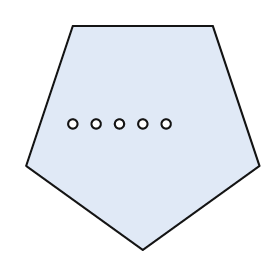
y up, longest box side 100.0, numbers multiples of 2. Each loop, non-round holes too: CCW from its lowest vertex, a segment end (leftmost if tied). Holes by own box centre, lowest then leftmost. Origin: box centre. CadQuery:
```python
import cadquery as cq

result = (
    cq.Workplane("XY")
    .moveTo(0.0, -48.0)
    .lineTo(50.0, -12.0)
    .lineTo(30.0, 48.0)
    .lineTo(-30.0, 48.0)
    .lineTo(-50.0, -12.0)
    .close()
    .moveTo(-30.0, 6.0)
    .circle(2.0)
    .moveTo(-20.0, 6.0)
    .circle(2.0)
    .moveTo(-10.0, 6.0)
    .circle(2.0)
    .moveTo(0.0, 6.0)
    .circle(2.0)
    .moveTo(10.0, 6.0)
    .circle(2.0)
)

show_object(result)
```